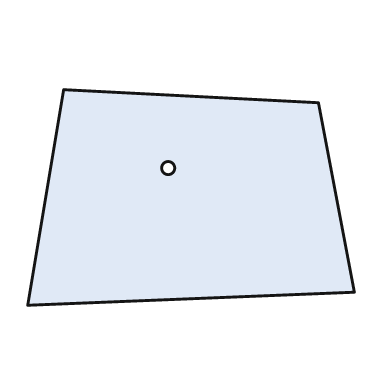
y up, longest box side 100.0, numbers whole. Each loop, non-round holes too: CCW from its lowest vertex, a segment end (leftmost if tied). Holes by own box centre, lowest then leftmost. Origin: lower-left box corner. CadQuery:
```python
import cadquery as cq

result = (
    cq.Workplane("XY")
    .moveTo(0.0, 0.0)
    .lineTo(100.0, 4.0)
    .lineTo(89.0, 62.0)
    .lineTo(11.0, 66.0)
    .close()
    .moveTo(43.0, 42.0)
    .circle(2.0)
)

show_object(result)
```